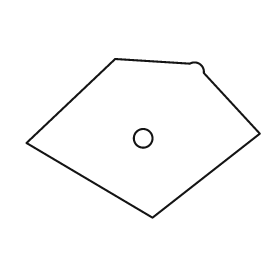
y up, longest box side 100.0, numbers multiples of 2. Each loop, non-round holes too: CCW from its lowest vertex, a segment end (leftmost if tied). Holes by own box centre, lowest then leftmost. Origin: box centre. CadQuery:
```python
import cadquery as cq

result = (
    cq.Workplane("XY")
    .moveTo(4.0, -34.0)
    .lineTo(50.0, 2.0)
    .lineTo(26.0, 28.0)
    .threePointArc((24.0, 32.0), (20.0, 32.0))
    .lineTo(-12.0, 34.0)
    .lineTo(-50.0, -2.0)
    .close()
    .moveTo(0.0, 0.0)
    .circle(4.0)
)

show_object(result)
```